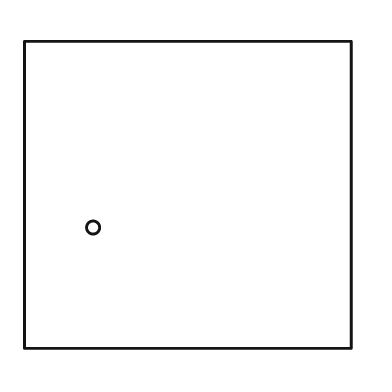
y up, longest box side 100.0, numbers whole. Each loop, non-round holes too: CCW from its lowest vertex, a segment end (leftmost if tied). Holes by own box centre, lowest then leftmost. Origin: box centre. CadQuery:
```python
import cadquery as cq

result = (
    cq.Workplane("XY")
    .moveTo(-50.0, -47.0)
    .lineTo(50.0, -47.0)
    .lineTo(50.0, 47.0)
    .lineTo(-50.0, 47.0)
    .close()
    .moveTo(-29.0, -10.0)
    .circle(2.0)
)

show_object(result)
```